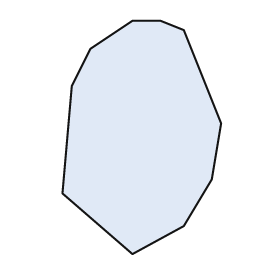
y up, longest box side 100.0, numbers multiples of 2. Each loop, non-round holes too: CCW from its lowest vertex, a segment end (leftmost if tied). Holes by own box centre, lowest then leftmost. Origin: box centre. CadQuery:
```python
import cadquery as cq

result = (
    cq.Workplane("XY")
    .moveTo(-4.0, -50.0)
    .lineTo(18.0, -38.0)
    .lineTo(30.0, -18.0)
    .lineTo(34.0, 6.0)
    .lineTo(18.0, 46.0)
    .lineTo(8.0, 50.0)
    .lineTo(-4.0, 50.0)
    .lineTo(-22.0, 38.0)
    .lineTo(-30.0, 22.0)
    .lineTo(-34.0, -24.0)
    .close()
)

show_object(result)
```